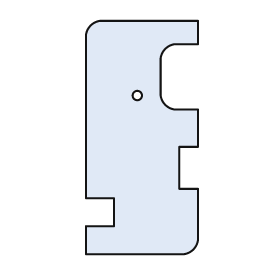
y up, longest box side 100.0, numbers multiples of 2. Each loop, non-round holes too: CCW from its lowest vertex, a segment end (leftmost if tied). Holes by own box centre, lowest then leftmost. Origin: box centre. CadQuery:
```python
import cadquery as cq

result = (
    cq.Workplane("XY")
    .moveTo(-24.0, -50.0)
    .lineTo(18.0, -50.0)
    .threePointArc((22.0, -48.0), (24.0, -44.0))
    .lineTo(24.0, -22.0)
    .lineTo(16.0, -22.0)
    .lineTo(16.0, -4.0)
    .lineTo(24.0, -4.0)
    .lineTo(24.0, 12.0)
    .lineTo(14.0, 12.0)
    .threePointArc((10.0, 14.0), (8.0, 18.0))
    .lineTo(8.0, 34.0)
    .threePointArc((10.0, 38.0), (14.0, 40.0))
    .lineTo(24.0, 40.0)
    .lineTo(24.0, 50.0)
    .lineTo(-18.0, 50.0)
    .threePointArc((-22.0, 48.0), (-24.0, 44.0))
    .lineTo(-24.0, -26.0)
    .lineTo(-12.0, -26.0)
    .lineTo(-12.0, -38.0)
    .lineTo(-24.0, -38.0)
    .close()
    .moveTo(-2.0, 18.0)
    .circle(2.0)
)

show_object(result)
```